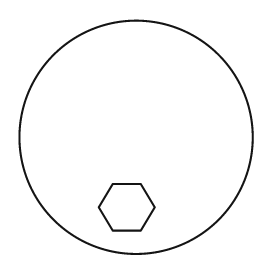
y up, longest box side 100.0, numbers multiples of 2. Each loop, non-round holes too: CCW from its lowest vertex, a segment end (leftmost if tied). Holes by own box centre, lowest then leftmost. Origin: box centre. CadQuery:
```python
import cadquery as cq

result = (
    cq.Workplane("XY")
    .moveTo(0.0, 0.0)
    .circle(50.0)
    .moveTo(-10.0, -40.0)
    .lineTo(2.0, -40.0)
    .lineTo(8.0, -30.0)
    .lineTo(2.0, -20.0)
    .lineTo(-10.0, -20.0)
    .lineTo(-16.0, -30.0)
    .close()
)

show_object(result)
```